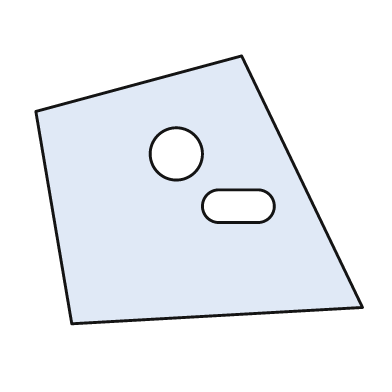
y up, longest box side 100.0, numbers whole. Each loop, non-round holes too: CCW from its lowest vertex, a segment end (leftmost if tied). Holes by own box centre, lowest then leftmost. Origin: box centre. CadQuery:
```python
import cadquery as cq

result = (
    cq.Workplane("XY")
    .moveTo(-39.0, -41.0)
    .lineTo(50.0, -36.0)
    .lineTo(13.0, 41.0)
    .lineTo(-50.0, 24.0)
    .close()
    .moveTo(6.0, -10.0)
    .lineTo(18.0, -10.0)
    .threePointArc((23.0, -5.0), (18.0, 0.0))
    .lineTo(6.0, 0.0)
    .threePointArc((1.0, -5.0), (6.0, -10.0))
    .close()
    .moveTo(-7.0, 11.0)
    .circle(8.0)
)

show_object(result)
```